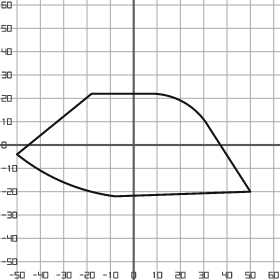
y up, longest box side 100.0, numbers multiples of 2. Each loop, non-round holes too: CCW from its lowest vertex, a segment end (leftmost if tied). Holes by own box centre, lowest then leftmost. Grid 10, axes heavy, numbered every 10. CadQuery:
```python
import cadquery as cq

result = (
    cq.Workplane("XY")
    .moveTo(-8.0, -22.0)
    .lineTo(50.0, -20.0)
    .lineTo(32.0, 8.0)
    .threePointArc((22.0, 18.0), (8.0, 22.0))
    .lineTo(-18.0, 22.0)
    .lineTo(-50.0, -4.0)
    .threePointArc((-30.0, -16.0), (-8.0, -22.0))
    .close()
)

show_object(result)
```